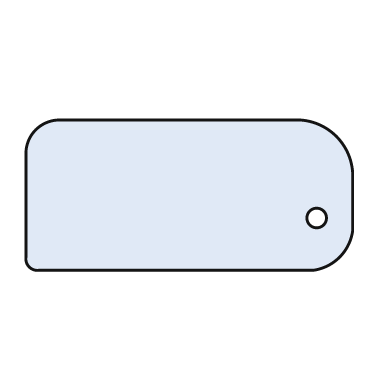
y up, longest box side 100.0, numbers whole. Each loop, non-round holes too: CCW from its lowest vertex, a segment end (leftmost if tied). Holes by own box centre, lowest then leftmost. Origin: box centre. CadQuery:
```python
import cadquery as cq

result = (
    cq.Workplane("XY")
    .moveTo(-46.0, -23.0)
    .lineTo(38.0, -23.0)
    .threePointArc((46.0, -19.0), (50.0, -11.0))
    .lineTo(50.0, 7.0)
    .threePointArc((45.0, 18.0), (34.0, 23.0))
    .lineTo(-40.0, 23.0)
    .threePointArc((-47.0, 20.0), (-50.0, 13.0))
    .lineTo(-50.0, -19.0)
    .threePointArc((-49.0, -22.0), (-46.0, -23.0))
    .close()
    .moveTo(39.0, -7.0)
    .circle(3.0)
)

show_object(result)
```